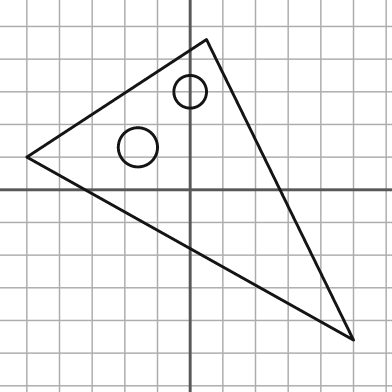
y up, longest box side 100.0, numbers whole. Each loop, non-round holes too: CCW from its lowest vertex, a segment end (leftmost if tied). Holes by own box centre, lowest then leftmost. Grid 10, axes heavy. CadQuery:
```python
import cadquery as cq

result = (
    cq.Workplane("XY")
    .moveTo(50.0, -46.0)
    .lineTo(5.0, 46.0)
    .lineTo(-50.0, 10.0)
    .close()
    .moveTo(-16.0, 13.0)
    .circle(6.0)
    .moveTo(0.0, 30.0)
    .circle(5.0)
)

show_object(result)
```